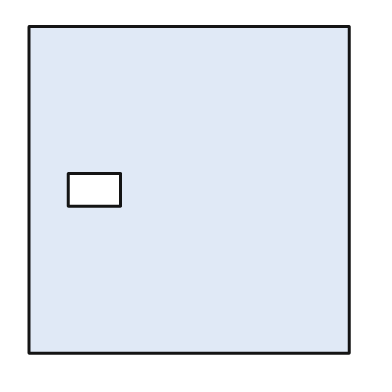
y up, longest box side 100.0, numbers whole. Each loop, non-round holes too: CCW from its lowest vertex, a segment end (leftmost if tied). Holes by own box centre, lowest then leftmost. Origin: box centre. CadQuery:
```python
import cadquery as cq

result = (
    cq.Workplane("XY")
    .moveTo(-49.0, -50.0)
    .lineTo(49.0, -50.0)
    .lineTo(49.0, 50.0)
    .lineTo(-49.0, 50.0)
    .close()
    .moveTo(-37.0, -5.0)
    .lineTo(-21.0, -5.0)
    .lineTo(-21.0, 5.0)
    .lineTo(-37.0, 5.0)
    .close()
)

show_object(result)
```